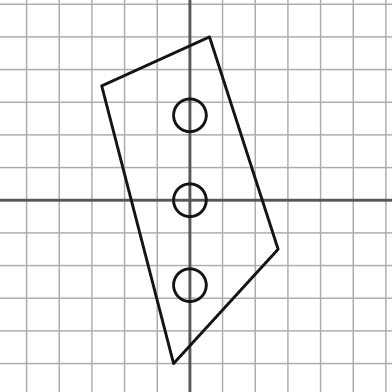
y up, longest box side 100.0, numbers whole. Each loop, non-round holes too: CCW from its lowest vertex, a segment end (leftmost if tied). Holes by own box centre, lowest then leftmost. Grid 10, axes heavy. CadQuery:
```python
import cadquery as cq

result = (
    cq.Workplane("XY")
    .moveTo(-5.0, -50.0)
    .lineTo(27.0, -15.0)
    .lineTo(6.0, 50.0)
    .lineTo(-27.0, 35.0)
    .close()
    .moveTo(0.0, -26.0)
    .circle(5.0)
    .moveTo(0.0, 0.0)
    .circle(5.0)
    .moveTo(0.0, 26.0)
    .circle(5.0)
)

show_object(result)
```